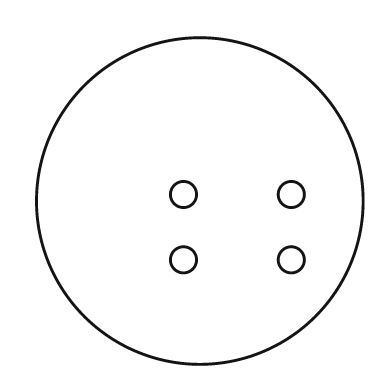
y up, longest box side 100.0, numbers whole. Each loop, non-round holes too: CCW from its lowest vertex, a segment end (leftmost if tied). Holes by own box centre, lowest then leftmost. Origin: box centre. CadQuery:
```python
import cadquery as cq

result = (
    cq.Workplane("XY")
    .moveTo(0.0, 0.0)
    .circle(50.0)
    .moveTo(-5.0, -18.0)
    .circle(4.0)
    .moveTo(28.0, -18.0)
    .circle(4.0)
    .moveTo(-5.0, 2.0)
    .circle(4.0)
    .moveTo(28.0, 2.0)
    .circle(4.0)
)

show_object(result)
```